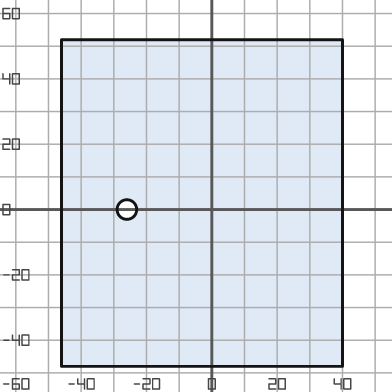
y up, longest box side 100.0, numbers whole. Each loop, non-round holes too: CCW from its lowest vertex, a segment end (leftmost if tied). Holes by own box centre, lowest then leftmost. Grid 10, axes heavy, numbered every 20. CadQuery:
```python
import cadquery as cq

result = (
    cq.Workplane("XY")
    .moveTo(-46.0, -48.0)
    .lineTo(40.0, -48.0)
    .lineTo(40.0, 52.0)
    .lineTo(-46.0, 52.0)
    .close()
    .moveTo(-26.0, 0.0)
    .circle(3.0)
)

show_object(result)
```